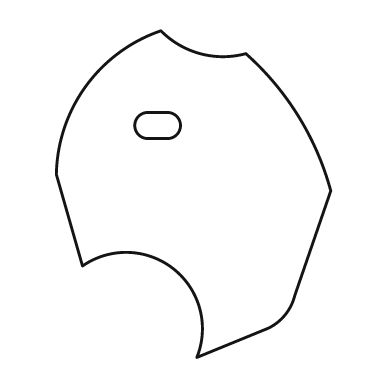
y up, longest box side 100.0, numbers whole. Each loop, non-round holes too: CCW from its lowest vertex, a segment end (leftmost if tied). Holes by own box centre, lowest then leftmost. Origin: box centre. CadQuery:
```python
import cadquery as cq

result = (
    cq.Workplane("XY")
    .moveTo(1.0, -50.0)
    .lineTo(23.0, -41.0)
    .threePointArc((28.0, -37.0), (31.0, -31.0))
    .lineTo(42.0, 1.0)
    .threePointArc((32.0, 24.0), (16.0, 43.0))
    .threePointArc((2.0, 43.0), (-10.0, 50.0))
    .threePointArc((-33.0, 33.0), (-42.0, 6.0))
    .lineTo(-34.0, -22.0)
    .threePointArc((-6.0, -23.0), (1.0, -50.0))
    .close()
    .moveTo(-14.0, 17.0)
    .lineTo(-8.0, 17.0)
    .threePointArc((-4.0, 21.0), (-8.0, 25.0))
    .lineTo(-14.0, 25.0)
    .threePointArc((-18.0, 21.0), (-14.0, 17.0))
    .close()
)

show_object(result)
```